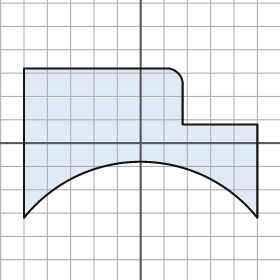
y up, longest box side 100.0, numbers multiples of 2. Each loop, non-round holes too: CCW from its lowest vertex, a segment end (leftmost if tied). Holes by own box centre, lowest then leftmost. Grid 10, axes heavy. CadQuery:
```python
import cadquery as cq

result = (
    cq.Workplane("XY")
    .moveTo(-50.0, -32.0)
    .threePointArc((0.0, -8.0), (50.0, -32.0))
    .lineTo(50.0, 8.0)
    .lineTo(18.0, 8.0)
    .lineTo(18.0, 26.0)
    .threePointArc((16.0, 30.0), (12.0, 32.0))
    .lineTo(-50.0, 32.0)
    .close()
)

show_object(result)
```